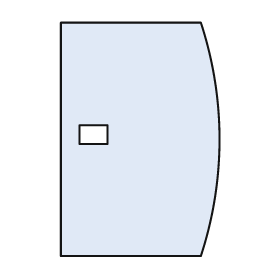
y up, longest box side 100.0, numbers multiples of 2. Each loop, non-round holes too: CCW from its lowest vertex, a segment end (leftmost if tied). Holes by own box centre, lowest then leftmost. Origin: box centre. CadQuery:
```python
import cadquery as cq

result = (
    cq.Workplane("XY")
    .moveTo(-34.0, -50.0)
    .lineTo(26.0, -50.0)
    .threePointArc((34.0, 0.0), (26.0, 50.0))
    .lineTo(-34.0, 50.0)
    .close()
    .moveTo(-26.0, -2.0)
    .lineTo(-14.0, -2.0)
    .lineTo(-14.0, 6.0)
    .lineTo(-26.0, 6.0)
    .close()
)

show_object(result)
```